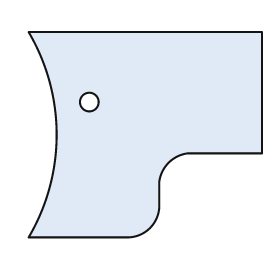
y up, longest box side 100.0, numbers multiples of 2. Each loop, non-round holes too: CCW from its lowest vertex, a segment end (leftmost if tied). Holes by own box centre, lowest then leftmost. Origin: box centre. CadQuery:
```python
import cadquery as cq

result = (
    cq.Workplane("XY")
    .moveTo(-50.0, -44.0)
    .lineTo(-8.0, -44.0)
    .threePointArc((2.0, -40.0), (6.0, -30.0))
    .lineTo(6.0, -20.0)
    .threePointArc((10.0, -12.0), (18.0, -8.0))
    .lineTo(50.0, -8.0)
    .lineTo(50.0, 44.0)
    .lineTo(-50.0, 44.0)
    .threePointArc((-38.0, 0.0), (-50.0, -44.0))
    .close()
    .moveTo(-24.0, 14.0)
    .circle(4.0)
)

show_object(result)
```